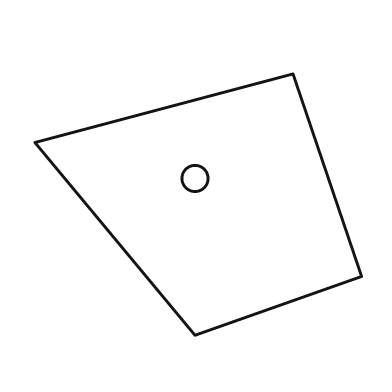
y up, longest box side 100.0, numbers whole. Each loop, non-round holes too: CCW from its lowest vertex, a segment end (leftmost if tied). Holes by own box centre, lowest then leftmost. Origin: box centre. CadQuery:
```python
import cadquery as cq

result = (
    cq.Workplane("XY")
    .moveTo(-1.0, -40.0)
    .lineTo(50.0, -22.0)
    .lineTo(29.0, 40.0)
    .lineTo(-50.0, 19.0)
    .close()
    .moveTo(-1.0, 8.0)
    .circle(4.0)
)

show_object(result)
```